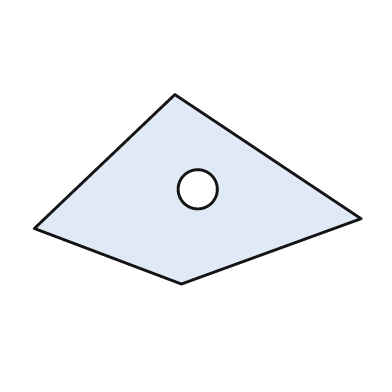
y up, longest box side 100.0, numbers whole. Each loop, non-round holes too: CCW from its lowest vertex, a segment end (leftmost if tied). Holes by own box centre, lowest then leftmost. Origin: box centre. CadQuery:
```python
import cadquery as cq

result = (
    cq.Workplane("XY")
    .moveTo(-5.0, -29.0)
    .lineTo(50.0, -9.0)
    .lineTo(-7.0, 29.0)
    .lineTo(-50.0, -12.0)
    .close()
    .moveTo(0.0, 0.0)
    .circle(6.0)
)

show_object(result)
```